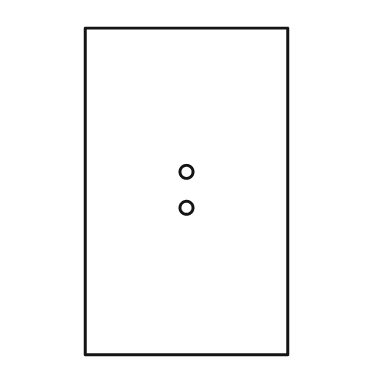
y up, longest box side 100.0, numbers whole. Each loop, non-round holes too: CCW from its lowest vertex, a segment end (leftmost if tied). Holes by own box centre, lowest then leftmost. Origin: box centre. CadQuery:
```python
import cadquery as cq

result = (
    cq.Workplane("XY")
    .moveTo(-31.0, -50.0)
    .lineTo(31.0, -50.0)
    .lineTo(31.0, 50.0)
    .lineTo(-31.0, 50.0)
    .close()
    .moveTo(0.0, -5.0)
    .circle(2.0)
    .moveTo(0.0, 6.0)
    .circle(2.0)
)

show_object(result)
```